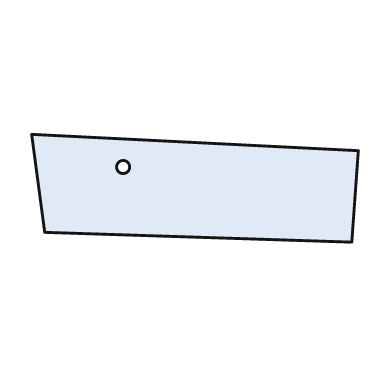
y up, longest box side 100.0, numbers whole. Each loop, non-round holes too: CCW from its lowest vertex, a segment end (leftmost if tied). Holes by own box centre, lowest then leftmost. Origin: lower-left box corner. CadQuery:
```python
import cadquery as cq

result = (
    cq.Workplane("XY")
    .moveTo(98.0, 0.0)
    .lineTo(100.0, 28.0)
    .lineTo(0.0, 33.0)
    .lineTo(4.0, 3.0)
    .close()
    .moveTo(28.0, 23.0)
    .circle(2.0)
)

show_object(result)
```